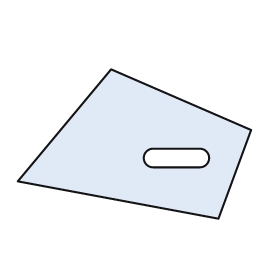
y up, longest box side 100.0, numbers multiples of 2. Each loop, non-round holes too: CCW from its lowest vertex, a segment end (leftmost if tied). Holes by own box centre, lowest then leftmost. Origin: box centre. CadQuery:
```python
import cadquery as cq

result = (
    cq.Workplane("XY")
    .moveTo(36.0, -32.0)
    .lineTo(50.0, 6.0)
    .lineTo(-10.0, 32.0)
    .lineTo(-50.0, -16.0)
    .close()
    .moveTo(8.0, -10.0)
    .lineTo(28.0, -10.0)
    .threePointArc((32.0, -6.0), (28.0, -2.0))
    .lineTo(8.0, -2.0)
    .threePointArc((4.0, -6.0), (8.0, -10.0))
    .close()
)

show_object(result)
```